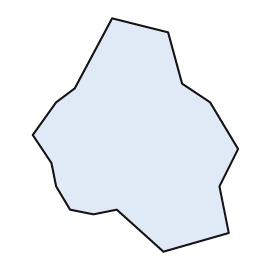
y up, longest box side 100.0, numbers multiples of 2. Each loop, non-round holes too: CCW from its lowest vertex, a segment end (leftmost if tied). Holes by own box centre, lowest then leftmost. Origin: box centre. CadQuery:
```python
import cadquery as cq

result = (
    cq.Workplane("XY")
    .moveTo(12.0, -50.0)
    .lineTo(40.0, -42.0)
    .lineTo(36.0, -22.0)
    .lineTo(44.0, -6.0)
    .lineTo(32.0, 14.0)
    .lineTo(20.0, 22.0)
    .lineTo(14.0, 44.0)
    .lineTo(-10.0, 50.0)
    .lineTo(-26.0, 20.0)
    .lineTo(-34.0, 14.0)
    .lineTo(-44.0, 0.0)
    .lineTo(-36.0, -12.0)
    .lineTo(-34.0, -22.0)
    .lineTo(-28.0, -32.0)
    .lineTo(-18.0, -34.0)
    .lineTo(-8.0, -32.0)
    .close()
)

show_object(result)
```